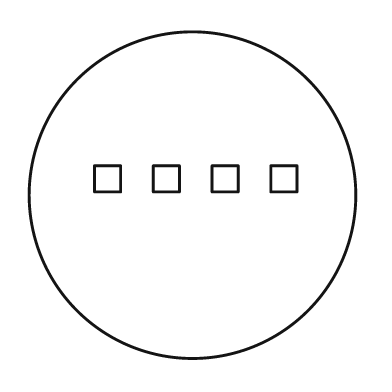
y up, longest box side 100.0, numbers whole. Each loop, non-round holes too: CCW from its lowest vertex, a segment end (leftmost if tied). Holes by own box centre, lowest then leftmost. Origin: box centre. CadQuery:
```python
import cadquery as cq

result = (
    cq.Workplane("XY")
    .moveTo(0.0, 0.0)
    .circle(50.0)
    .moveTo(-30.0, 1.0)
    .lineTo(-22.0, 1.0)
    .lineTo(-22.0, 9.0)
    .lineTo(-30.0, 9.0)
    .close()
    .moveTo(-12.0, 1.0)
    .lineTo(-4.0, 1.0)
    .lineTo(-4.0, 9.0)
    .lineTo(-12.0, 9.0)
    .close()
    .moveTo(6.0, 1.0)
    .lineTo(14.0, 1.0)
    .lineTo(14.0, 9.0)
    .lineTo(6.0, 9.0)
    .close()
    .moveTo(24.0, 1.0)
    .lineTo(32.0, 1.0)
    .lineTo(32.0, 9.0)
    .lineTo(24.0, 9.0)
    .close()
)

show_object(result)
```